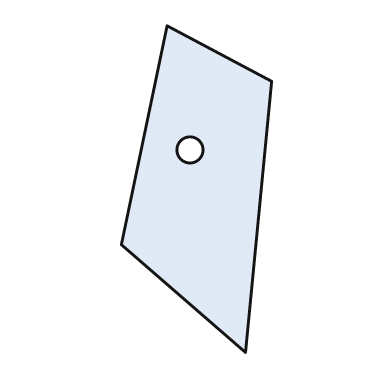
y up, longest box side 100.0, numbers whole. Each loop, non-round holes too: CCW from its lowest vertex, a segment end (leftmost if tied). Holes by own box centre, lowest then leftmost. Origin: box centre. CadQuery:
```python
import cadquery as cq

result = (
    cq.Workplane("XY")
    .moveTo(15.0, -50.0)
    .lineTo(23.0, 33.0)
    .lineTo(-9.0, 50.0)
    .lineTo(-23.0, -17.0)
    .close()
    .moveTo(-2.0, 12.0)
    .circle(4.0)
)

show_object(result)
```